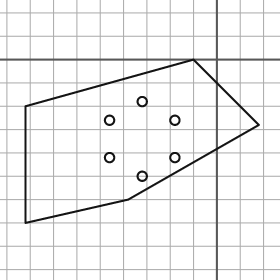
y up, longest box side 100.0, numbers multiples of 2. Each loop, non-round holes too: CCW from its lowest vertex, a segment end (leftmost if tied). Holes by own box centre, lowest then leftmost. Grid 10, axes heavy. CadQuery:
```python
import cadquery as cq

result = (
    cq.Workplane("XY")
    .moveTo(-82.0, -70.0)
    .lineTo(-38.0, -60.0)
    .lineTo(18.0, -28.0)
    .lineTo(-10.0, 0.0)
    .lineTo(-82.0, -20.0)
    .close()
    .moveTo(-32.0, -50.0)
    .circle(2.0)
    .moveTo(-46.0, -42.0)
    .circle(2.0)
    .moveTo(-18.0, -42.0)
    .circle(2.0)
    .moveTo(-46.0, -26.0)
    .circle(2.0)
    .moveTo(-18.0, -26.0)
    .circle(2.0)
    .moveTo(-32.0, -18.0)
    .circle(2.0)
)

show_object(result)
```